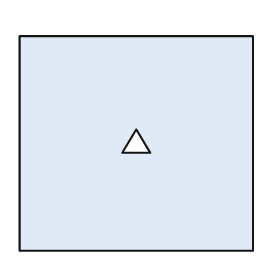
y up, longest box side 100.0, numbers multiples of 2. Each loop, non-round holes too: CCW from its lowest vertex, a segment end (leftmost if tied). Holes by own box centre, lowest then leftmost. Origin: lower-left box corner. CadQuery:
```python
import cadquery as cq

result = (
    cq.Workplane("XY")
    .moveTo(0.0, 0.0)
    .lineTo(100.0, 0.0)
    .lineTo(100.0, 92.0)
    .lineTo(0.0, 92.0)
    .close()
    .moveTo(44.0, 42.0)
    .lineTo(56.0, 42.0)
    .lineTo(50.0, 52.0)
    .close()
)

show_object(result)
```